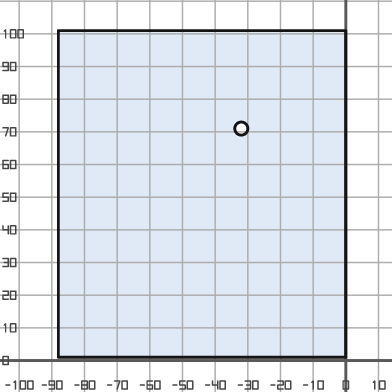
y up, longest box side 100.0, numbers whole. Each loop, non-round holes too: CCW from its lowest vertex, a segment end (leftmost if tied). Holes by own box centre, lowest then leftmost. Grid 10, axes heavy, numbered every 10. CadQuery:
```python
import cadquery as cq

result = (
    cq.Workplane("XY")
    .moveTo(-88.0, 1.0)
    .lineTo(0.0, 1.0)
    .lineTo(0.0, 101.0)
    .lineTo(-88.0, 101.0)
    .close()
    .moveTo(-32.0, 71.0)
    .circle(2.0)
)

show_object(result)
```